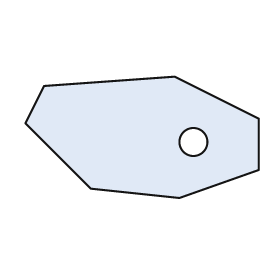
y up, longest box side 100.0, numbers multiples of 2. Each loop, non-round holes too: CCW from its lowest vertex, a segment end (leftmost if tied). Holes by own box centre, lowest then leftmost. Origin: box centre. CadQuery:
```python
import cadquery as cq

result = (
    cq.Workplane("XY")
    .moveTo(16.0, -26.0)
    .lineTo(50.0, -14.0)
    .lineTo(50.0, 8.0)
    .lineTo(14.0, 26.0)
    .lineTo(-42.0, 22.0)
    .lineTo(-50.0, 6.0)
    .lineTo(-22.0, -22.0)
    .close()
    .moveTo(22.0, -2.0)
    .circle(6.0)
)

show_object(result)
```